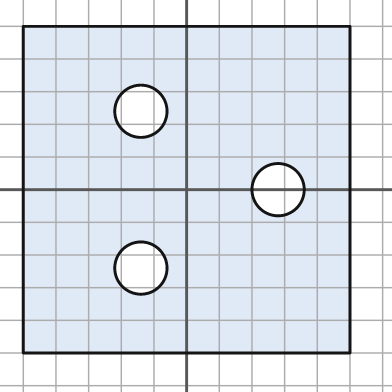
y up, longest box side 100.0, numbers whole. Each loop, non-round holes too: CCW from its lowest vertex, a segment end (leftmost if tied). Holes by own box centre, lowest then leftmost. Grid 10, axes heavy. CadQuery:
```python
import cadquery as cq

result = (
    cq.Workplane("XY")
    .moveTo(-50.0, -50.0)
    .lineTo(50.0, -50.0)
    .lineTo(50.0, 50.0)
    .lineTo(-50.0, 50.0)
    .close()
    .moveTo(-14.0, -24.0)
    .circle(8.0)
    .moveTo(28.0, 0.0)
    .circle(8.0)
    .moveTo(-14.0, 24.0)
    .circle(8.0)
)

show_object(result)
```